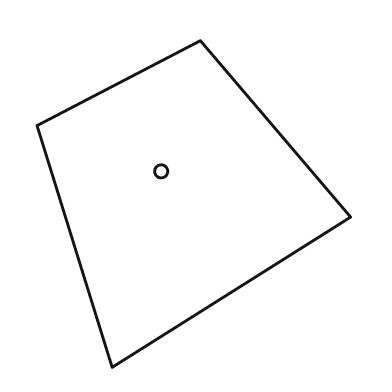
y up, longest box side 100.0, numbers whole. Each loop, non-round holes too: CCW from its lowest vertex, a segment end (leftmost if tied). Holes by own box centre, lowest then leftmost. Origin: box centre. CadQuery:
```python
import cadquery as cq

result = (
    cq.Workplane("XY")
    .moveTo(-25.0, -50.0)
    .lineTo(48.0, -4.0)
    .lineTo(2.0, 50.0)
    .lineTo(-48.0, 24.0)
    .close()
    .moveTo(-10.0, 10.0)
    .circle(2.0)
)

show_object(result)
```